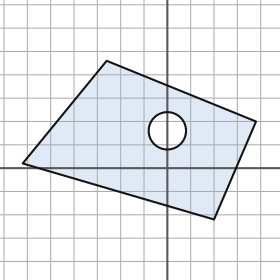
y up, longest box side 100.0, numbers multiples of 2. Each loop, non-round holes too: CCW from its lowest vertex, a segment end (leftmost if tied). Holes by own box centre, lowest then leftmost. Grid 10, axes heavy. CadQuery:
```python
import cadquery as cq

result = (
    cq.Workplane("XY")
    .moveTo(20.0, -22.0)
    .lineTo(38.0, 20.0)
    .lineTo(-26.0, 46.0)
    .lineTo(-62.0, 2.0)
    .close()
    .moveTo(0.0, 16.0)
    .circle(8.0)
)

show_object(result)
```